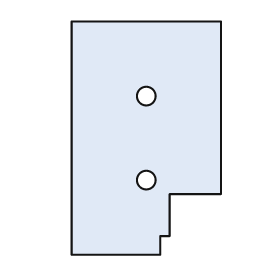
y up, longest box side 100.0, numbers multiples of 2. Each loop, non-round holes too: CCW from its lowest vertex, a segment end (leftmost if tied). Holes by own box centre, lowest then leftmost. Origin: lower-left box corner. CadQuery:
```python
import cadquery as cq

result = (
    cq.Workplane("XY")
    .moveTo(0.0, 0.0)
    .lineTo(38.0, 0.0)
    .lineTo(38.0, 8.0)
    .lineTo(42.0, 8.0)
    .lineTo(42.0, 26.0)
    .lineTo(64.0, 26.0)
    .lineTo(64.0, 100.0)
    .lineTo(0.0, 100.0)
    .close()
    .moveTo(32.0, 32.0)
    .circle(4.0)
    .moveTo(32.0, 68.0)
    .circle(4.0)
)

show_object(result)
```